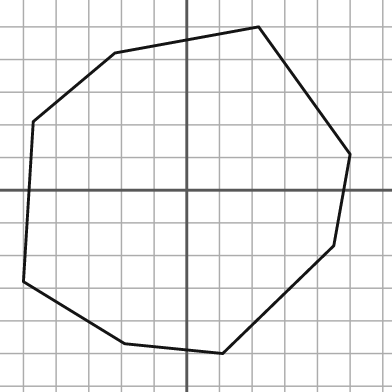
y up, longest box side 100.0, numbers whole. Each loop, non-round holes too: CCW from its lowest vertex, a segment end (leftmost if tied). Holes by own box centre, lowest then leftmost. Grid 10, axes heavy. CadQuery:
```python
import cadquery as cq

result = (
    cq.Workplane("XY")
    .moveTo(11.0, -50.0)
    .lineTo(45.0, -17.0)
    .lineTo(50.0, 11.0)
    .lineTo(22.0, 50.0)
    .lineTo(-22.0, 42.0)
    .lineTo(-47.0, 21.0)
    .lineTo(-50.0, -28.0)
    .lineTo(-19.0, -47.0)
    .close()
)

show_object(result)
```